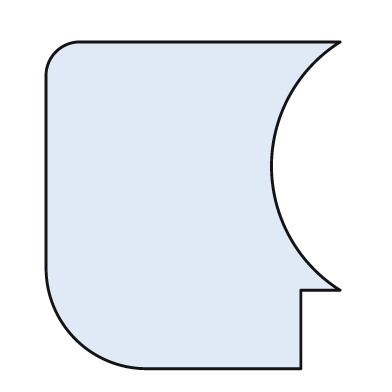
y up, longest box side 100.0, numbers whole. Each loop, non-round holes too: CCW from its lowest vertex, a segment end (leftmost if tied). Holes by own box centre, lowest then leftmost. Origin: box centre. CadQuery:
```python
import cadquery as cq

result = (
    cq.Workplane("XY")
    .moveTo(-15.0, -50.0)
    .lineTo(33.0, -50.0)
    .lineTo(33.0, -26.0)
    .lineTo(45.0, -26.0)
    .threePointArc((24.0, 12.0), (45.0, 50.0))
    .lineTo(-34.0, 50.0)
    .threePointArc((-42.0, 47.0), (-45.0, 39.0))
    .lineTo(-45.0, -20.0)
    .threePointArc((-36.0, -41.0), (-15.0, -50.0))
    .close()
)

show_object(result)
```